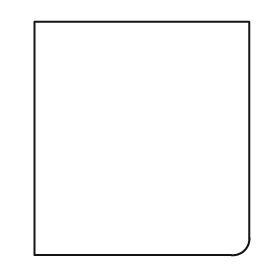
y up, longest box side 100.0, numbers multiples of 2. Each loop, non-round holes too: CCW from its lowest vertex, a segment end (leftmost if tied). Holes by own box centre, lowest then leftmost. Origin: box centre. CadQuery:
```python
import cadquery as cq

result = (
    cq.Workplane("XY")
    .moveTo(-46.0, -50.0)
    .lineTo(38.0, -50.0)
    .threePointArc((44.0, -48.0), (46.0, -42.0))
    .lineTo(46.0, 50.0)
    .lineTo(-46.0, 50.0)
    .close()
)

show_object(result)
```